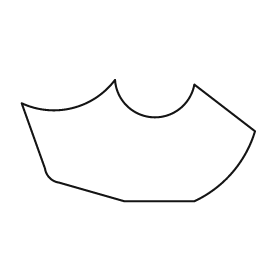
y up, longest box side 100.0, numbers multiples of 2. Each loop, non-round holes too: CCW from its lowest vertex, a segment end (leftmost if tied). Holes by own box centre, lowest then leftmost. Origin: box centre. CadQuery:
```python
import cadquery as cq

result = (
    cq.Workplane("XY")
    .moveTo(-6.0, -26.0)
    .lineTo(24.0, -26.0)
    .threePointArc((40.0, -14.0), (50.0, 4.0))
    .lineTo(24.0, 24.0)
    .threePointArc((6.0, 10.0), (-10.0, 26.0))
    .threePointArc((-28.0, 14.0), (-50.0, 16.0))
    .lineTo(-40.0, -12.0)
    .threePointArc((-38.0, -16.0), (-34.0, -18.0))
    .close()
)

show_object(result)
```